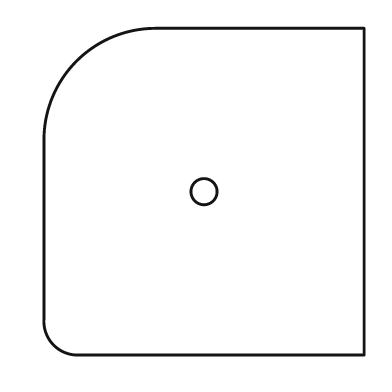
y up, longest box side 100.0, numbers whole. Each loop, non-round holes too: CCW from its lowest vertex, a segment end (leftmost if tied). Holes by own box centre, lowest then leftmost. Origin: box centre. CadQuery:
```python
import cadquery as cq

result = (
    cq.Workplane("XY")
    .moveTo(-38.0, -50.0)
    .lineTo(49.0, -50.0)
    .lineTo(49.0, 50.0)
    .lineTo(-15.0, 50.0)
    .threePointArc((-39.0, 40.0), (-49.0, 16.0))
    .lineTo(-49.0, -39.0)
    .threePointArc((-46.0, -47.0), (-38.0, -50.0))
    .close()
    .moveTo(0.0, 0.0)
    .circle(4.0)
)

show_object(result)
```